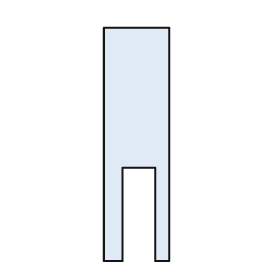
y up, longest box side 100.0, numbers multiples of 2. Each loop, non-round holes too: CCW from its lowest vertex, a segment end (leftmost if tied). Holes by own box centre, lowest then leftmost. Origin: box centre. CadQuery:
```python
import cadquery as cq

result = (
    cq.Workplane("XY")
    .moveTo(-14.0, -50.0)
    .lineTo(-6.0, -50.0)
    .lineTo(-6.0, -10.0)
    .lineTo(8.0, -10.0)
    .lineTo(8.0, -50.0)
    .lineTo(14.0, -50.0)
    .lineTo(14.0, 50.0)
    .lineTo(-14.0, 50.0)
    .close()
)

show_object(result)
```